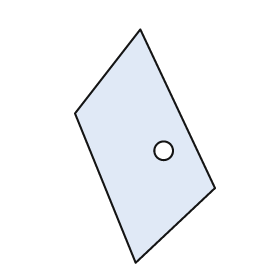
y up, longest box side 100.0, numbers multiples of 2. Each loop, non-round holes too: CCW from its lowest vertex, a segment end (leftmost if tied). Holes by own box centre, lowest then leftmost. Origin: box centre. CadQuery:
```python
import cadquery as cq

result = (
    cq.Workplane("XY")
    .moveTo(-4.0, -50.0)
    .lineTo(30.0, -18.0)
    .lineTo(-2.0, 50.0)
    .lineTo(-30.0, 14.0)
    .close()
    .moveTo(8.0, -2.0)
    .circle(4.0)
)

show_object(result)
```